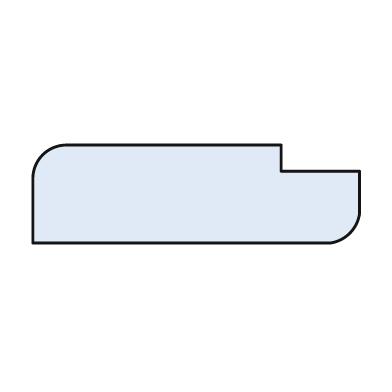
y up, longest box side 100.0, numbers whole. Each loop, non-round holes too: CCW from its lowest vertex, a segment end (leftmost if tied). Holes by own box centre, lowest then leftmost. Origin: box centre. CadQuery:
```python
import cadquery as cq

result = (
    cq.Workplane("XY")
    .moveTo(-50.0, -15.0)
    .lineTo(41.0, -15.0)
    .threePointArc((47.0, -12.0), (50.0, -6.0))
    .lineTo(50.0, 7.0)
    .lineTo(26.0, 7.0)
    .lineTo(26.0, 15.0)
    .lineTo(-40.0, 15.0)
    .threePointArc((-47.0, 12.0), (-50.0, 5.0))
    .close()
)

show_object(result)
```